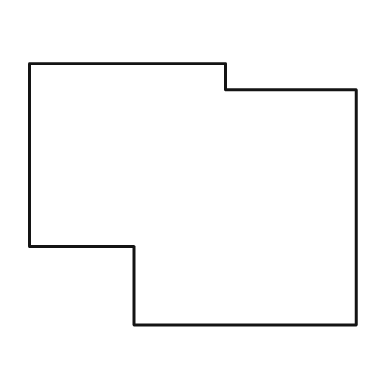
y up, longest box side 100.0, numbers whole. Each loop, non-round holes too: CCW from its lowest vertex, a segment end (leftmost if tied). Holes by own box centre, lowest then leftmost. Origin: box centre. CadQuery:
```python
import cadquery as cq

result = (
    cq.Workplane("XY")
    .moveTo(-18.0, -40.0)
    .lineTo(50.0, -40.0)
    .lineTo(50.0, 32.0)
    .lineTo(10.0, 32.0)
    .lineTo(10.0, 40.0)
    .lineTo(-50.0, 40.0)
    .lineTo(-50.0, -16.0)
    .lineTo(-18.0, -16.0)
    .close()
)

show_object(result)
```